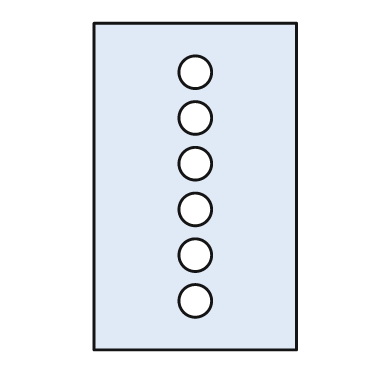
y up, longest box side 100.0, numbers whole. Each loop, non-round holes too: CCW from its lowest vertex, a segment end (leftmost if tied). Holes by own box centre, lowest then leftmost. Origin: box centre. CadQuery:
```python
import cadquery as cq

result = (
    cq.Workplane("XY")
    .moveTo(-31.0, -50.0)
    .lineTo(31.0, -50.0)
    .lineTo(31.0, 50.0)
    .lineTo(-31.0, 50.0)
    .close()
    .moveTo(0.0, -35.0)
    .circle(5.0)
    .moveTo(0.0, -21.0)
    .circle(5.0)
    .moveTo(0.0, -7.0)
    .circle(5.0)
    .moveTo(0.0, 7.0)
    .circle(5.0)
    .moveTo(0.0, 21.0)
    .circle(5.0)
    .moveTo(0.0, 35.0)
    .circle(5.0)
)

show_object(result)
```